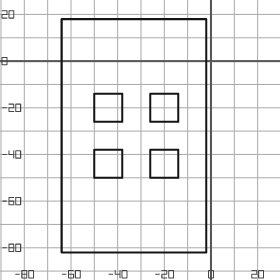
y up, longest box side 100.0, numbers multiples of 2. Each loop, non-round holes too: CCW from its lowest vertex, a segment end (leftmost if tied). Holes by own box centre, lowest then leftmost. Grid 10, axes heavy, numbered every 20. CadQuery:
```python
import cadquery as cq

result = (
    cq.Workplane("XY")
    .moveTo(-64.0, -82.0)
    .lineTo(-2.0, -82.0)
    .lineTo(-2.0, 18.0)
    .lineTo(-64.0, 18.0)
    .close()
    .moveTo(-50.0, -50.0)
    .lineTo(-38.0, -50.0)
    .lineTo(-38.0, -38.0)
    .lineTo(-50.0, -38.0)
    .close()
    .moveTo(-26.0, -50.0)
    .lineTo(-14.0, -50.0)
    .lineTo(-14.0, -38.0)
    .lineTo(-26.0, -38.0)
    .close()
    .moveTo(-50.0, -26.0)
    .lineTo(-38.0, -26.0)
    .lineTo(-38.0, -14.0)
    .lineTo(-50.0, -14.0)
    .close()
    .moveTo(-26.0, -26.0)
    .lineTo(-14.0, -26.0)
    .lineTo(-14.0, -14.0)
    .lineTo(-26.0, -14.0)
    .close()
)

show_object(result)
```